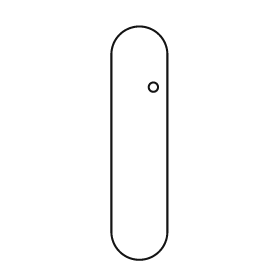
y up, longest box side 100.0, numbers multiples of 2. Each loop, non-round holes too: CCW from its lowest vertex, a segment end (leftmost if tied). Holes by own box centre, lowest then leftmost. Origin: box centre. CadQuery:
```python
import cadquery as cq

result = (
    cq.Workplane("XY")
    .moveTo(-12.0, -38.0)
    .threePointArc((0.0, -50.0), (12.0, -38.0))
    .lineTo(12.0, 38.0)
    .threePointArc((0.0, 50.0), (-12.0, 38.0))
    .close()
    .moveTo(6.0, 24.0)
    .circle(2.0)
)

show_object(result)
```